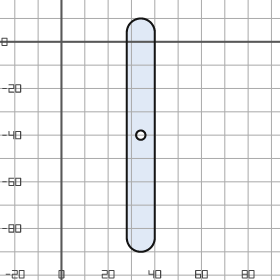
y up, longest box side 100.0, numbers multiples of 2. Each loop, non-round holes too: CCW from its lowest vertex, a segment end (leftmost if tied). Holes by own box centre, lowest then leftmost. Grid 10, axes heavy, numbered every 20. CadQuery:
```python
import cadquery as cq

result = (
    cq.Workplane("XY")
    .moveTo(28.0, -84.0)
    .threePointArc((34.0, -90.0), (40.0, -84.0))
    .lineTo(40.0, 4.0)
    .threePointArc((34.0, 10.0), (28.0, 4.0))
    .close()
    .moveTo(34.0, -40.0)
    .circle(2.0)
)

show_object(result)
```